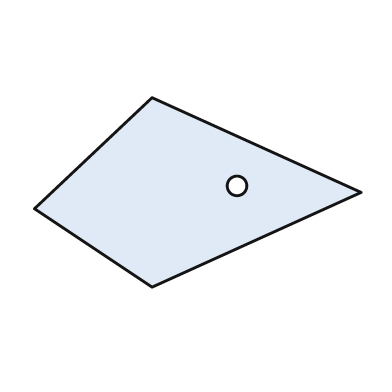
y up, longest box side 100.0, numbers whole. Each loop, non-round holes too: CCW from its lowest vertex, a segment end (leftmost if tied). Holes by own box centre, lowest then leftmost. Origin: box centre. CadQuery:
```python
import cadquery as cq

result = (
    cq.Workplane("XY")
    .moveTo(-14.0, -29.0)
    .lineTo(50.0, 0.0)
    .lineTo(-14.0, 29.0)
    .lineTo(-50.0, -5.0)
    .close()
    .moveTo(12.0, 2.0)
    .circle(3.0)
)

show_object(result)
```